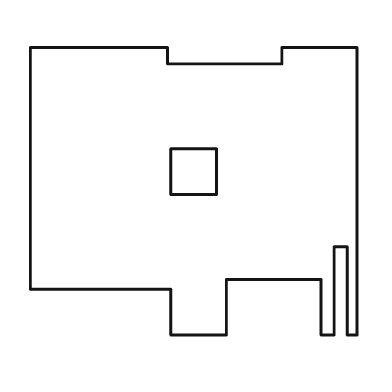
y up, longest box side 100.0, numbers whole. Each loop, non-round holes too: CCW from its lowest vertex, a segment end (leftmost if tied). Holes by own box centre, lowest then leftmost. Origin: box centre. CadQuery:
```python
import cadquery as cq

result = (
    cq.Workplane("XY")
    .moveTo(-7.0, -44.0)
    .lineTo(10.0, -44.0)
    .lineTo(10.0, -27.0)
    .lineTo(39.0, -27.0)
    .lineTo(39.0, -44.0)
    .lineTo(43.0, -44.0)
    .lineTo(43.0, -17.0)
    .lineTo(47.0, -17.0)
    .lineTo(47.0, -44.0)
    .lineTo(50.0, -44.0)
    .lineTo(50.0, 44.0)
    .lineTo(27.0, 44.0)
    .lineTo(27.0, 39.0)
    .lineTo(-8.0, 39.0)
    .lineTo(-8.0, 44.0)
    .lineTo(-50.0, 44.0)
    .lineTo(-50.0, -30.0)
    .lineTo(-7.0, -30.0)
    .close()
    .moveTo(-7.0, -1.0)
    .lineTo(7.0, -1.0)
    .lineTo(7.0, 13.0)
    .lineTo(-7.0, 13.0)
    .close()
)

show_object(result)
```